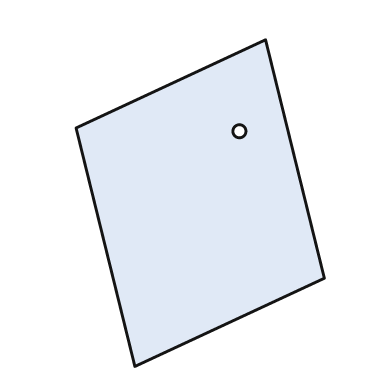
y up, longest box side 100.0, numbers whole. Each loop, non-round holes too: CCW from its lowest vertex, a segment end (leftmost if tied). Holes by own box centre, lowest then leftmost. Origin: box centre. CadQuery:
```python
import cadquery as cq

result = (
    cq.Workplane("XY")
    .moveTo(-20.0, -50.0)
    .lineTo(38.0, -23.0)
    .lineTo(20.0, 50.0)
    .lineTo(-38.0, 23.0)
    .close()
    .moveTo(12.0, 22.0)
    .circle(2.0)
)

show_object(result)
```